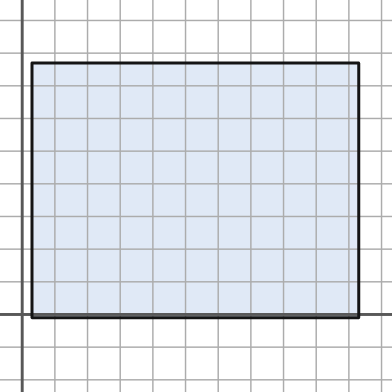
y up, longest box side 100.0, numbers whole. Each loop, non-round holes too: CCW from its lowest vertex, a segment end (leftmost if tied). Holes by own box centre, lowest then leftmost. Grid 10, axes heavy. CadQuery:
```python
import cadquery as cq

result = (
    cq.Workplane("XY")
    .moveTo(3.0, -1.0)
    .lineTo(103.0, -1.0)
    .lineTo(103.0, 77.0)
    .lineTo(3.0, 77.0)
    .close()
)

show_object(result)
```